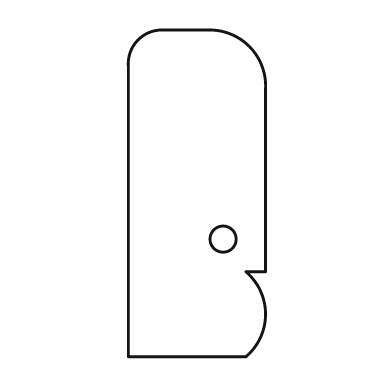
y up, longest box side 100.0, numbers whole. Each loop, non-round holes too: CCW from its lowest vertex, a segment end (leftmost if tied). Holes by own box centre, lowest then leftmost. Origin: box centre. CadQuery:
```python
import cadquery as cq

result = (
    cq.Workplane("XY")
    .moveTo(-21.0, -50.0)
    .lineTo(15.0, -50.0)
    .threePointArc((21.0, -37.0), (15.0, -24.0))
    .lineTo(21.0, -24.0)
    .lineTo(21.0, 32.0)
    .threePointArc((16.0, 45.0), (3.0, 50.0))
    .lineTo(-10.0, 50.0)
    .threePointArc((-18.0, 47.0), (-21.0, 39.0))
    .close()
    .moveTo(8.0, -14.0)
    .circle(4.0)
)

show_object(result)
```